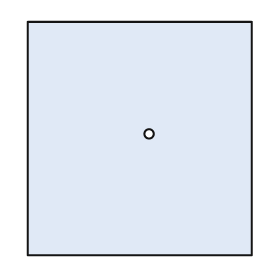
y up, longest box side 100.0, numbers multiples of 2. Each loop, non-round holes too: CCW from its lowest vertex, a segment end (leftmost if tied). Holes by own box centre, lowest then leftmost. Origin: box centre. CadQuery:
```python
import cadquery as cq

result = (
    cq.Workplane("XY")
    .moveTo(-48.0, -50.0)
    .lineTo(48.0, -50.0)
    .lineTo(48.0, 50.0)
    .lineTo(-48.0, 50.0)
    .close()
    .moveTo(4.0, 2.0)
    .circle(2.0)
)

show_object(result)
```